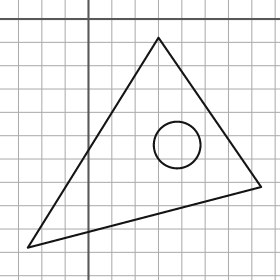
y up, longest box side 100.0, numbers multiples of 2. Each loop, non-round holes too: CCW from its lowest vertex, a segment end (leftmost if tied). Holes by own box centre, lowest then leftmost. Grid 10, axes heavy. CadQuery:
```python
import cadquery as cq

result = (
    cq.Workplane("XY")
    .moveTo(-26.0, -98.0)
    .lineTo(74.0, -72.0)
    .lineTo(30.0, -8.0)
    .close()
    .moveTo(38.0, -54.0)
    .circle(10.0)
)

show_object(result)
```